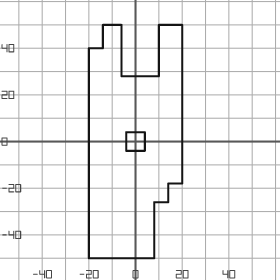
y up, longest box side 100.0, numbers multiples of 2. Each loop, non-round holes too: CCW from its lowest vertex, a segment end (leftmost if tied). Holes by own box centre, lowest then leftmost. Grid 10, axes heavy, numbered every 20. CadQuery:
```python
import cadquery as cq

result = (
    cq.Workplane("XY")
    .moveTo(-20.0, -50.0)
    .lineTo(8.0, -50.0)
    .lineTo(8.0, -26.0)
    .lineTo(14.0, -26.0)
    .lineTo(14.0, -18.0)
    .lineTo(20.0, -18.0)
    .lineTo(20.0, 50.0)
    .lineTo(10.0, 50.0)
    .lineTo(10.0, 28.0)
    .lineTo(-6.0, 28.0)
    .lineTo(-6.0, 50.0)
    .lineTo(-14.0, 50.0)
    .lineTo(-14.0, 40.0)
    .lineTo(-20.0, 40.0)
    .close()
    .moveTo(-4.0, -4.0)
    .lineTo(4.0, -4.0)
    .lineTo(4.0, 4.0)
    .lineTo(-4.0, 4.0)
    .close()
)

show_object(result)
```